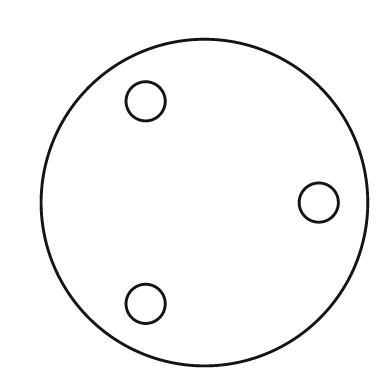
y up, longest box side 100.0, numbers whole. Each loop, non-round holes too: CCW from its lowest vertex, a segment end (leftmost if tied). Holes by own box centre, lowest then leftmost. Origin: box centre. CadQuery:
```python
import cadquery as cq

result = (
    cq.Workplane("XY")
    .moveTo(0.0, 0.0)
    .circle(50.0)
    .moveTo(-18.0, -31.0)
    .circle(6.0)
    .moveTo(35.0, 0.0)
    .circle(6.0)
    .moveTo(-18.0, 31.0)
    .circle(6.0)
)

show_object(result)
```